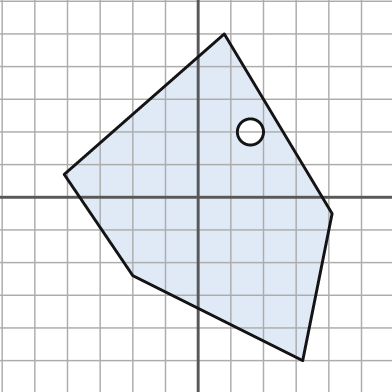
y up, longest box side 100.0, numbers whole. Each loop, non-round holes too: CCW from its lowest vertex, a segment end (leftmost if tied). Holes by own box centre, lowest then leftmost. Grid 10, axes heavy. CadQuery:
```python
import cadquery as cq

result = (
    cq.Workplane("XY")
    .moveTo(32.0, -50.0)
    .lineTo(41.0, -5.0)
    .lineTo(8.0, 50.0)
    .lineTo(-41.0, 7.0)
    .lineTo(-20.0, -24.0)
    .close()
    .moveTo(16.0, 20.0)
    .circle(4.0)
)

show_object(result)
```